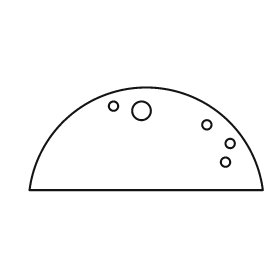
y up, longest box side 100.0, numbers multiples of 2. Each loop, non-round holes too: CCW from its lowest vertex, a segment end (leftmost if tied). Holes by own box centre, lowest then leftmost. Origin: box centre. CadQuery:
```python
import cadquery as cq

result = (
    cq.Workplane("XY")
    .moveTo(-50.0, -22.0)
    .lineTo(50.0, -22.0)
    .threePointArc((0.0, 22.0), (-50.0, -22.0))
    .close()
    .moveTo(34.0, -10.0)
    .circle(2.0)
    .moveTo(36.0, -2.0)
    .circle(2.0)
    .moveTo(26.0, 6.0)
    .circle(2.0)
    .moveTo(-2.0, 12.0)
    .circle(4.0)
    .moveTo(-14.0, 14.0)
    .circle(2.0)
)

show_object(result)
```